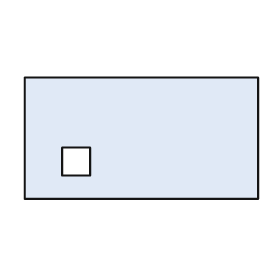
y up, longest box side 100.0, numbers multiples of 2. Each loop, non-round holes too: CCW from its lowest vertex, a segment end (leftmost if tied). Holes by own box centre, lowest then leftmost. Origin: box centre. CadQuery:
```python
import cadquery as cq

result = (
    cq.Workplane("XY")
    .moveTo(-50.0, -26.0)
    .lineTo(50.0, -26.0)
    .lineTo(50.0, 26.0)
    .lineTo(-50.0, 26.0)
    .close()
    .moveTo(-34.0, -16.0)
    .lineTo(-22.0, -16.0)
    .lineTo(-22.0, -4.0)
    .lineTo(-34.0, -4.0)
    .close()
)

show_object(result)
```